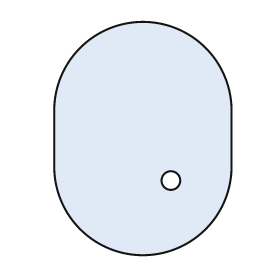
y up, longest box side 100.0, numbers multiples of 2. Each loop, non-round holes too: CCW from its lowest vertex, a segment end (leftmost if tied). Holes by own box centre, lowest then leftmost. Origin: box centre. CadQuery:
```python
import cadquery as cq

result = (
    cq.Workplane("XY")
    .moveTo(-38.0, -12.0)
    .threePointArc((0.0, -50.0), (38.0, -12.0))
    .lineTo(38.0, 12.0)
    .threePointArc((0.0, 50.0), (-38.0, 12.0))
    .close()
    .moveTo(12.0, -18.0)
    .circle(4.0)
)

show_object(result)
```